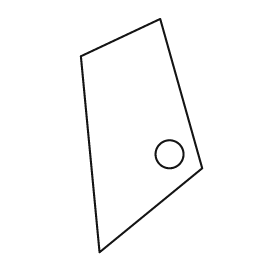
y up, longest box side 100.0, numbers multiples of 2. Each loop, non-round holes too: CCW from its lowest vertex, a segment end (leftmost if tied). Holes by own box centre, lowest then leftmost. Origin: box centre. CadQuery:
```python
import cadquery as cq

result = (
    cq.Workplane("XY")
    .moveTo(-18.0, -50.0)
    .lineTo(26.0, -14.0)
    .lineTo(8.0, 50.0)
    .lineTo(-26.0, 34.0)
    .close()
    .moveTo(12.0, -8.0)
    .circle(6.0)
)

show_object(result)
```